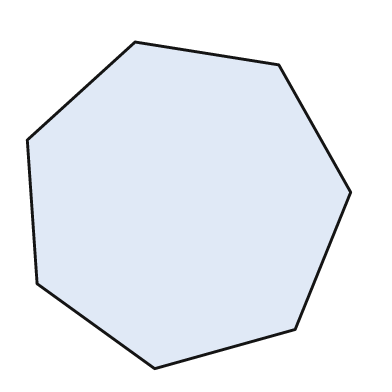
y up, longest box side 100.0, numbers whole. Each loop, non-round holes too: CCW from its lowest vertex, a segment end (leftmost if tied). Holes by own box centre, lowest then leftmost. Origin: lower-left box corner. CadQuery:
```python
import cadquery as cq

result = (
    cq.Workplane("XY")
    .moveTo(39.0, 0.0)
    .lineTo(82.0, 12.0)
    .lineTo(99.0, 54.0)
    .lineTo(77.0, 93.0)
    .lineTo(33.0, 100.0)
    .lineTo(0.0, 70.0)
    .lineTo(3.0, 26.0)
    .close()
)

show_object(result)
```